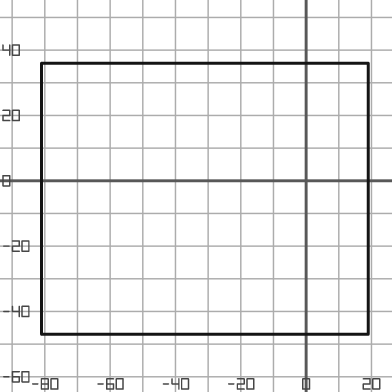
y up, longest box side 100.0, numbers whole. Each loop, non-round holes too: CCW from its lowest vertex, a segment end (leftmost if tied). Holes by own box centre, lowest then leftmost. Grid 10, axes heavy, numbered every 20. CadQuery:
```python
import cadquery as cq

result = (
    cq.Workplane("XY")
    .moveTo(-81.0, -47.0)
    .lineTo(19.0, -47.0)
    .lineTo(19.0, 36.0)
    .lineTo(-81.0, 36.0)
    .close()
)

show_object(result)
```